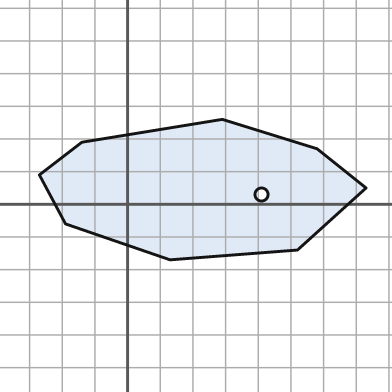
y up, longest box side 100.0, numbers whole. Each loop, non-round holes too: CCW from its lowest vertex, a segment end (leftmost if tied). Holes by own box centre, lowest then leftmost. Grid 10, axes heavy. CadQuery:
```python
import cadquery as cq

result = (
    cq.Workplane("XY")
    .moveTo(13.0, -17.0)
    .lineTo(52.0, -14.0)
    .lineTo(73.0, 5.0)
    .lineTo(58.0, 17.0)
    .lineTo(29.0, 26.0)
    .lineTo(-14.0, 19.0)
    .lineTo(-27.0, 9.0)
    .lineTo(-19.0, -6.0)
    .close()
    .moveTo(41.0, 3.0)
    .circle(2.0)
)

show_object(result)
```